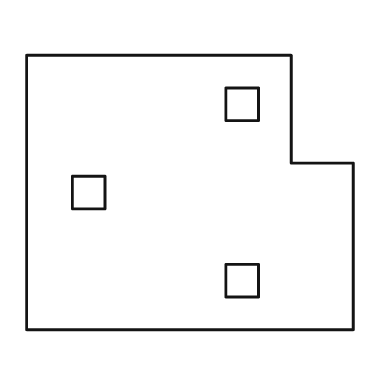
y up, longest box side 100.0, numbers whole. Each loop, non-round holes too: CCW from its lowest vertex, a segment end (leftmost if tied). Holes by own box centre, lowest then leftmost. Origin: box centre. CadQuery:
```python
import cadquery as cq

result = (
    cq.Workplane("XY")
    .moveTo(-50.0, -42.0)
    .lineTo(50.0, -42.0)
    .lineTo(50.0, 9.0)
    .lineTo(31.0, 9.0)
    .lineTo(31.0, 42.0)
    .lineTo(-50.0, 42.0)
    .close()
    .moveTo(11.0, -32.0)
    .lineTo(21.0, -32.0)
    .lineTo(21.0, -22.0)
    .lineTo(11.0, -22.0)
    .close()
    .moveTo(-36.0, -5.0)
    .lineTo(-26.0, -5.0)
    .lineTo(-26.0, 5.0)
    .lineTo(-36.0, 5.0)
    .close()
    .moveTo(11.0, 22.0)
    .lineTo(21.0, 22.0)
    .lineTo(21.0, 32.0)
    .lineTo(11.0, 32.0)
    .close()
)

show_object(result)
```